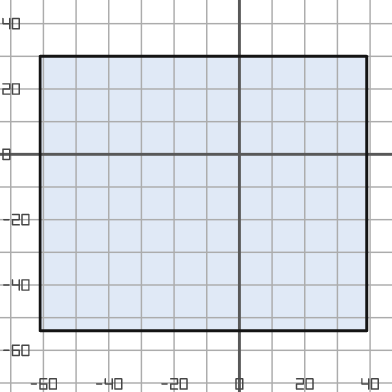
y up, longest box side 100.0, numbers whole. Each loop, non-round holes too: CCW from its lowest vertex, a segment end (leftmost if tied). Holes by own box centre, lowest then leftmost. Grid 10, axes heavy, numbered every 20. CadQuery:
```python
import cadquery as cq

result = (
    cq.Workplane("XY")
    .moveTo(-61.0, -54.0)
    .lineTo(39.0, -54.0)
    .lineTo(39.0, 30.0)
    .lineTo(-61.0, 30.0)
    .close()
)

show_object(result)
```